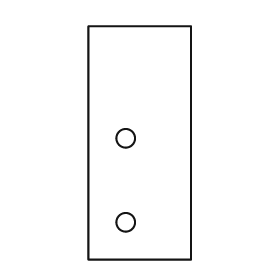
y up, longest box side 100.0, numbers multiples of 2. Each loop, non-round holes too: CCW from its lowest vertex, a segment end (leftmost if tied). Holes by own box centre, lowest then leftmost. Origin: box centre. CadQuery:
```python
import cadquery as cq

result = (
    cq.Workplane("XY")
    .moveTo(-22.0, -50.0)
    .lineTo(22.0, -50.0)
    .lineTo(22.0, 50.0)
    .lineTo(-22.0, 50.0)
    .close()
    .moveTo(-6.0, -34.0)
    .circle(4.0)
    .moveTo(-6.0, 2.0)
    .circle(4.0)
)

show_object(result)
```